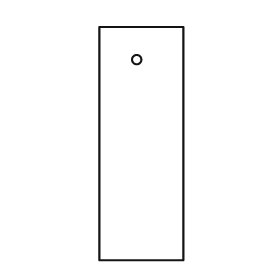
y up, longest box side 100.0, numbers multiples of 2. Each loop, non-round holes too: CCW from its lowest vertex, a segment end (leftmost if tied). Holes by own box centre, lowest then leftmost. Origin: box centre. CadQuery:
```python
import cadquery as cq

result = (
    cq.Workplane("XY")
    .moveTo(-18.0, -50.0)
    .lineTo(18.0, -50.0)
    .lineTo(18.0, 50.0)
    .lineTo(-18.0, 50.0)
    .close()
    .moveTo(-2.0, 36.0)
    .circle(2.0)
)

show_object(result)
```